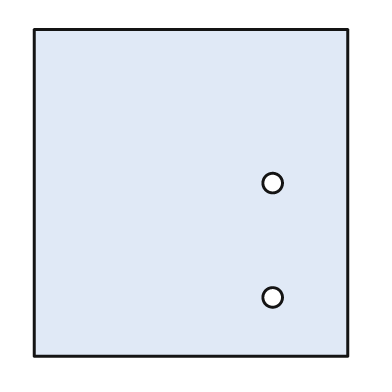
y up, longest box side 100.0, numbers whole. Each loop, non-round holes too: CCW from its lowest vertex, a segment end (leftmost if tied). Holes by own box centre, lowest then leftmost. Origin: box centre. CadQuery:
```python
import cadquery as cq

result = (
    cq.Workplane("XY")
    .moveTo(-48.0, -50.0)
    .lineTo(48.0, -50.0)
    .lineTo(48.0, 50.0)
    .lineTo(-48.0, 50.0)
    .close()
    .moveTo(25.0, -32.0)
    .circle(3.0)
    .moveTo(25.0, 3.0)
    .circle(3.0)
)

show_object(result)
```